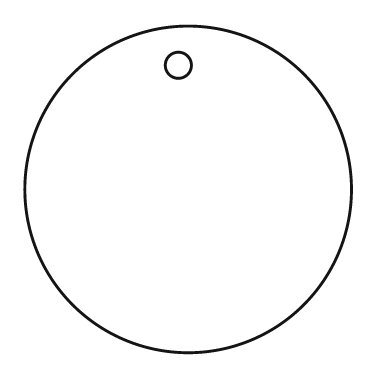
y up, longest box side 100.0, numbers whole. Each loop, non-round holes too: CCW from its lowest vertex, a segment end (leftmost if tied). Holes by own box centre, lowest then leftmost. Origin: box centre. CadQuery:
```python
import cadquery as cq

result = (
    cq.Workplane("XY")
    .moveTo(0.0, 0.0)
    .circle(50.0)
    .moveTo(-3.0, 38.0)
    .circle(4.0)
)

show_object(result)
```